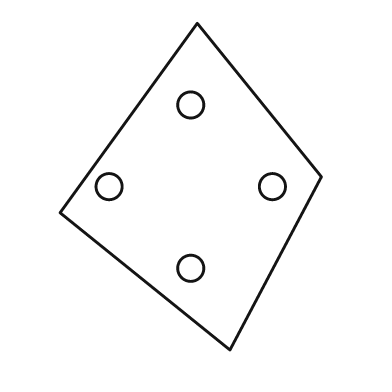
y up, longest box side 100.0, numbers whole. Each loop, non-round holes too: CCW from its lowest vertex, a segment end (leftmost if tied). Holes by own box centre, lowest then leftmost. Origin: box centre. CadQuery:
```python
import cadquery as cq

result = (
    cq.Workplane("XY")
    .moveTo(12.0, -50.0)
    .lineTo(40.0, 3.0)
    .lineTo(2.0, 50.0)
    .lineTo(-40.0, -8.0)
    .close()
    .moveTo(0.0, -25.0)
    .circle(4.0)
    .moveTo(-25.0, 0.0)
    .circle(4.0)
    .moveTo(25.0, 0.0)
    .circle(4.0)
    .moveTo(0.0, 25.0)
    .circle(4.0)
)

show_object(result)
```